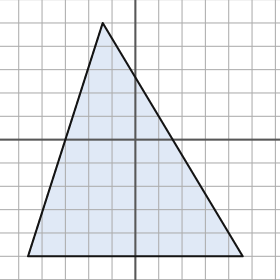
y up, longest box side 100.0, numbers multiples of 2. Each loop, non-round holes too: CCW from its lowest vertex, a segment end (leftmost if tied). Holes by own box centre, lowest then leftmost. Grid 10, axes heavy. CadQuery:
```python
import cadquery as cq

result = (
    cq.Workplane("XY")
    .moveTo(-46.0, -50.0)
    .lineTo(46.0, -50.0)
    .lineTo(-14.0, 50.0)
    .close()
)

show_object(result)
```